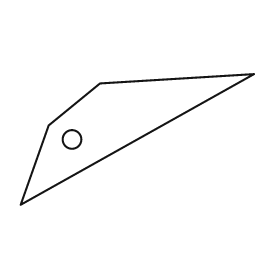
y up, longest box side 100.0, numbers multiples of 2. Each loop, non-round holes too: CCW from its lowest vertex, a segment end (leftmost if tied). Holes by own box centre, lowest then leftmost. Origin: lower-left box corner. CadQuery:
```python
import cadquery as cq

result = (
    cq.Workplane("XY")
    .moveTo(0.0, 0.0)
    .lineTo(100.0, 56.0)
    .lineTo(34.0, 52.0)
    .lineTo(12.0, 34.0)
    .close()
    .moveTo(22.0, 28.0)
    .circle(4.0)
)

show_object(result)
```